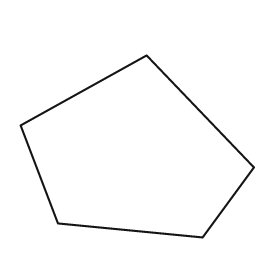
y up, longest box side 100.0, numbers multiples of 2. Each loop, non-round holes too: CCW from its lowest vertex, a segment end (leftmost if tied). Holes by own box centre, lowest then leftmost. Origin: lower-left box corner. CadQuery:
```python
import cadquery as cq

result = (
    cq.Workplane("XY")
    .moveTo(78.0, 0.0)
    .lineTo(100.0, 30.0)
    .lineTo(54.0, 78.0)
    .lineTo(0.0, 48.0)
    .lineTo(16.0, 6.0)
    .close()
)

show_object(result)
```